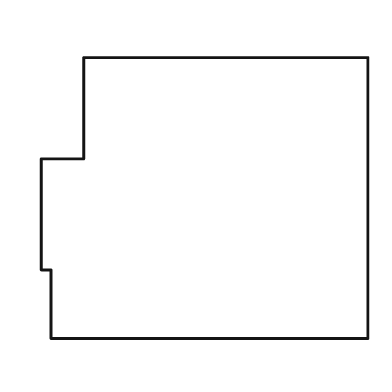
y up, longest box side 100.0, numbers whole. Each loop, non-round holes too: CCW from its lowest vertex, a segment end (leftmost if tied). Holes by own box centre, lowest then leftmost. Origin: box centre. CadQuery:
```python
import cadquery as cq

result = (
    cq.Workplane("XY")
    .moveTo(-47.0, -43.0)
    .lineTo(50.0, -43.0)
    .lineTo(50.0, 43.0)
    .lineTo(-37.0, 43.0)
    .lineTo(-37.0, 12.0)
    .lineTo(-50.0, 12.0)
    .lineTo(-50.0, -22.0)
    .lineTo(-47.0, -22.0)
    .close()
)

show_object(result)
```